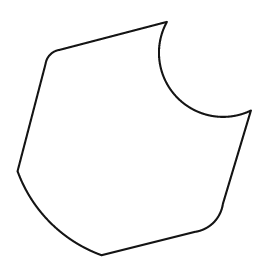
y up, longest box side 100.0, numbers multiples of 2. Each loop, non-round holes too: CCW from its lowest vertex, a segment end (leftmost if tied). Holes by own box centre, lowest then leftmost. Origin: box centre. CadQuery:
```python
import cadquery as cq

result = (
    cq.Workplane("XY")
    .moveTo(-14.0, -50.0)
    .lineTo(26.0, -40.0)
    .threePointArc((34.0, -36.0), (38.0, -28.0))
    .lineTo(50.0, 12.0)
    .threePointArc((18.0, 18.0), (14.0, 50.0))
    .lineTo(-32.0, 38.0)
    .threePointArc((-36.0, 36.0), (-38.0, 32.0))
    .lineTo(-50.0, -14.0)
    .threePointArc((-36.0, -36.0), (-14.0, -50.0))
    .close()
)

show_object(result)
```